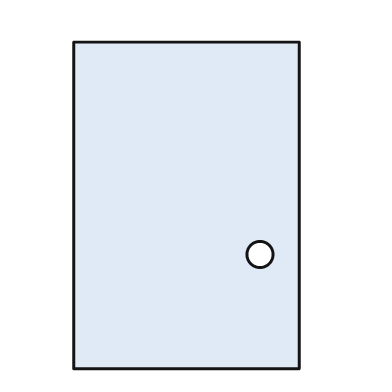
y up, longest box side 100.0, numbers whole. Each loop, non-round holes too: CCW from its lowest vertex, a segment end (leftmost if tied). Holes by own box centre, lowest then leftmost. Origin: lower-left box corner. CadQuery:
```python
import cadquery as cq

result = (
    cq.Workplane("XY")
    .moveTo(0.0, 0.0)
    .lineTo(69.0, 0.0)
    .lineTo(69.0, 100.0)
    .lineTo(0.0, 100.0)
    .close()
    .moveTo(57.0, 35.0)
    .circle(4.0)
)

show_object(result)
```